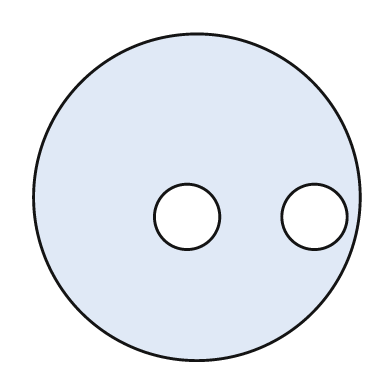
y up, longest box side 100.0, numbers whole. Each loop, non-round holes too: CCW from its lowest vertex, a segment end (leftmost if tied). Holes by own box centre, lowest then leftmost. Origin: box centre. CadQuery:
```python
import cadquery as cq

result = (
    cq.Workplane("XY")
    .moveTo(0.0, 0.0)
    .circle(50.0)
    .moveTo(-3.0, -6.0)
    .circle(10.0)
    .moveTo(36.0, -6.0)
    .circle(10.0)
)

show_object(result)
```